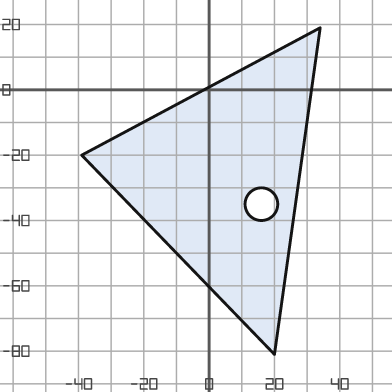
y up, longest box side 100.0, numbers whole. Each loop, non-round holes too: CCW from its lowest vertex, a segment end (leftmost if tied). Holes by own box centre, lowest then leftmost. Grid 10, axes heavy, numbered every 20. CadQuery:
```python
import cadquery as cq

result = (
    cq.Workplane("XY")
    .moveTo(20.0, -81.0)
    .lineTo(34.0, 19.0)
    .lineTo(-39.0, -20.0)
    .close()
    .moveTo(16.0, -35.0)
    .circle(5.0)
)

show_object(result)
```